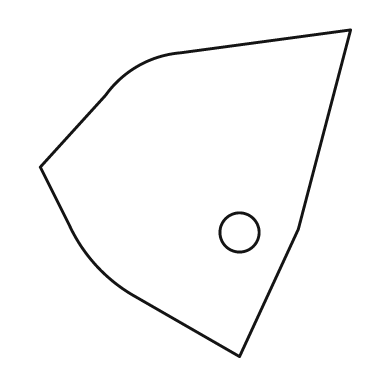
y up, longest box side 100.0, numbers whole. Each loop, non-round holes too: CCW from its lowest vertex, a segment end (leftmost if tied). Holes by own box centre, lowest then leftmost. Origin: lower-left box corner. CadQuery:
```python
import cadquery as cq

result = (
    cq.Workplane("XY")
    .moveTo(61.0, 0.0)
    .lineTo(79.0, 39.0)
    .lineTo(95.0, 100.0)
    .lineTo(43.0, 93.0)
    .threePointArc((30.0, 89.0), (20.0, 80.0))
    .lineTo(0.0, 58.0)
    .lineTo(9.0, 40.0)
    .threePointArc((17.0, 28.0), (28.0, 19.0))
    .close()
    .moveTo(61.0, 38.0)
    .circle(6.0)
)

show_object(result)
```